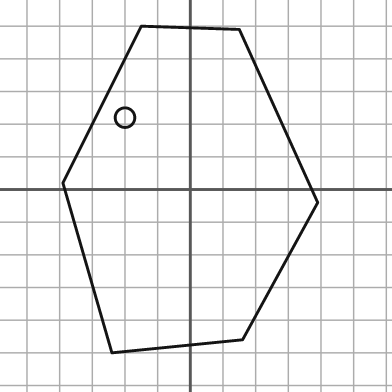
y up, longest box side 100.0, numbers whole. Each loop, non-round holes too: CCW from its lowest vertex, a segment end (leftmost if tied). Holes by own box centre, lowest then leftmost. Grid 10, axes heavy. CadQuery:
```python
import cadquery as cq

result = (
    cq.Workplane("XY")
    .moveTo(-24.0, -50.0)
    .lineTo(16.0, -46.0)
    .lineTo(39.0, -4.0)
    .lineTo(15.0, 49.0)
    .lineTo(-15.0, 50.0)
    .lineTo(-39.0, 2.0)
    .close()
    .moveTo(-20.0, 22.0)
    .circle(3.0)
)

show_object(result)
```